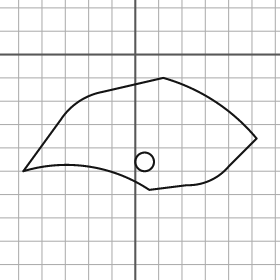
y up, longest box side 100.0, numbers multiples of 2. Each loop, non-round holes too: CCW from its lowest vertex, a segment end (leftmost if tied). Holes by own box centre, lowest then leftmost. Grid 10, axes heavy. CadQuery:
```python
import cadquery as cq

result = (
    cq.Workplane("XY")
    .moveTo(6.0, -58.0)
    .lineTo(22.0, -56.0)
    .threePointArc((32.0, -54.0), (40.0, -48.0))
    .lineTo(52.0, -36.0)
    .threePointArc((34.0, -20.0), (12.0, -10.0))
    .lineTo(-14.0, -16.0)
    .threePointArc((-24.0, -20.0), (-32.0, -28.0))
    .lineTo(-48.0, -50.0)
    .threePointArc((-20.0, -48.0), (6.0, -58.0))
    .close()
    .moveTo(4.0, -46.0)
    .circle(4.0)
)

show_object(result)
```